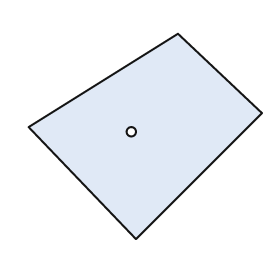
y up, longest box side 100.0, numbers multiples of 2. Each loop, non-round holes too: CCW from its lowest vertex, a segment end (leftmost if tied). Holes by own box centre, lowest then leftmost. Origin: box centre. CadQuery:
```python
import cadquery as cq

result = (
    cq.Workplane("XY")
    .moveTo(-4.0, -44.0)
    .lineTo(50.0, 10.0)
    .lineTo(14.0, 44.0)
    .lineTo(-50.0, 4.0)
    .close()
    .moveTo(-6.0, 2.0)
    .circle(2.0)
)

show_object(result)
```